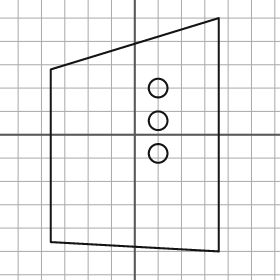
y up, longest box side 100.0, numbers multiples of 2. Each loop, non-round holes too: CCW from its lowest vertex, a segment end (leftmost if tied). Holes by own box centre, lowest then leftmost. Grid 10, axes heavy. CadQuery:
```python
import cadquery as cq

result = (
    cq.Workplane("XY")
    .moveTo(36.0, -50.0)
    .lineTo(36.0, 50.0)
    .lineTo(-36.0, 28.0)
    .lineTo(-36.0, -46.0)
    .close()
    .moveTo(10.0, -8.0)
    .circle(4.0)
    .moveTo(10.0, 6.0)
    .circle(4.0)
    .moveTo(10.0, 20.0)
    .circle(4.0)
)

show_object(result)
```